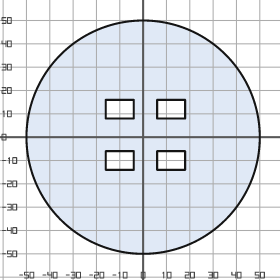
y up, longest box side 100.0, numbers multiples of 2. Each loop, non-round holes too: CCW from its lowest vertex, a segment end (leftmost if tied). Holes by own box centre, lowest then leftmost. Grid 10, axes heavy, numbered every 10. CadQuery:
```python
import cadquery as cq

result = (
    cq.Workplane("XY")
    .moveTo(0.0, 0.0)
    .circle(50.0)
    .moveTo(-16.0, -14.0)
    .lineTo(-4.0, -14.0)
    .lineTo(-4.0, -6.0)
    .lineTo(-16.0, -6.0)
    .close()
    .moveTo(6.0, -14.0)
    .lineTo(18.0, -14.0)
    .lineTo(18.0, -6.0)
    .lineTo(6.0, -6.0)
    .close()
    .moveTo(-16.0, 8.0)
    .lineTo(-4.0, 8.0)
    .lineTo(-4.0, 16.0)
    .lineTo(-16.0, 16.0)
    .close()
    .moveTo(6.0, 8.0)
    .lineTo(18.0, 8.0)
    .lineTo(18.0, 16.0)
    .lineTo(6.0, 16.0)
    .close()
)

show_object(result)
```